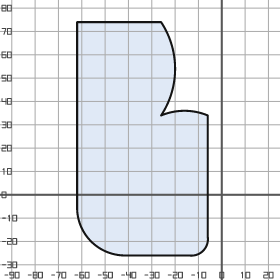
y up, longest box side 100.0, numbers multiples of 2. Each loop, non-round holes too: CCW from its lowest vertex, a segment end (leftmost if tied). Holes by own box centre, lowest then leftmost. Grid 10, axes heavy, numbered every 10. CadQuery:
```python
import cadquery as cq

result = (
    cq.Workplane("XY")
    .moveTo(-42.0, -26.0)
    .lineTo(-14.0, -26.0)
    .threePointArc((-8.0, -24.0), (-6.0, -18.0))
    .lineTo(-6.0, 34.0)
    .threePointArc((-16.0, 36.0), (-26.0, 34.0))
    .threePointArc((-20.0, 54.0), (-26.0, 74.0))
    .lineTo(-62.0, 74.0)
    .lineTo(-62.0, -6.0)
    .threePointArc((-56.0, -20.0), (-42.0, -26.0))
    .close()
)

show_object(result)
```